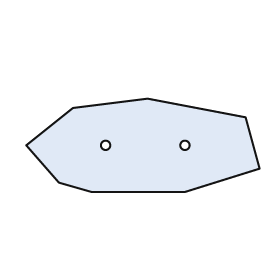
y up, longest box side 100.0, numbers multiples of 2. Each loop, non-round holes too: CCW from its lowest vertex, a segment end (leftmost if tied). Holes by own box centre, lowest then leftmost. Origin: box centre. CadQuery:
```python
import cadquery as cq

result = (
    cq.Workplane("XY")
    .moveTo(-22.0, -20.0)
    .lineTo(18.0, -20.0)
    .lineTo(50.0, -10.0)
    .lineTo(44.0, 12.0)
    .lineTo(2.0, 20.0)
    .lineTo(-30.0, 16.0)
    .lineTo(-50.0, 0.0)
    .lineTo(-36.0, -16.0)
    .close()
    .moveTo(-16.0, 0.0)
    .circle(2.0)
    .moveTo(18.0, 0.0)
    .circle(2.0)
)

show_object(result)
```